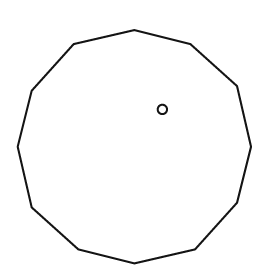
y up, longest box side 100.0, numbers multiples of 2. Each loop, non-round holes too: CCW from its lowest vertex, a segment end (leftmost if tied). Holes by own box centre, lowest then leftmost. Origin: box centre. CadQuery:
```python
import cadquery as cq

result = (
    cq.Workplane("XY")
    .moveTo(0.0, -50.0)
    .lineTo(26.0, -44.0)
    .lineTo(44.0, -24.0)
    .lineTo(50.0, 0.0)
    .lineTo(44.0, 26.0)
    .lineTo(24.0, 44.0)
    .lineTo(0.0, 50.0)
    .lineTo(-26.0, 44.0)
    .lineTo(-44.0, 24.0)
    .lineTo(-50.0, 0.0)
    .lineTo(-44.0, -26.0)
    .lineTo(-24.0, -44.0)
    .close()
    .moveTo(12.0, 16.0)
    .circle(2.0)
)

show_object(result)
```